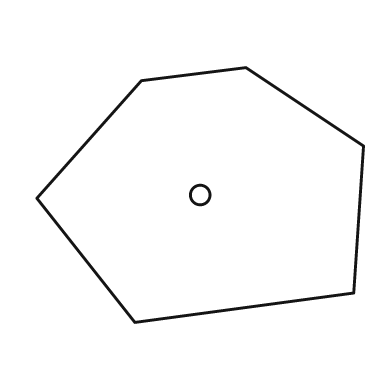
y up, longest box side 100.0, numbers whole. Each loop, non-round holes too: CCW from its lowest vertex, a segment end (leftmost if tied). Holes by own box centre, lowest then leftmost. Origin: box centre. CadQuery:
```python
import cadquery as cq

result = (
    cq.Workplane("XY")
    .moveTo(-20.0, -39.0)
    .lineTo(47.0, -30.0)
    .lineTo(50.0, 15.0)
    .lineTo(14.0, 39.0)
    .lineTo(-18.0, 35.0)
    .lineTo(-50.0, -1.0)
    .close()
    .moveTo(0.0, 0.0)
    .circle(3.0)
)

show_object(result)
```